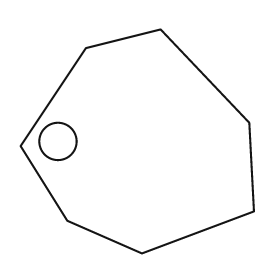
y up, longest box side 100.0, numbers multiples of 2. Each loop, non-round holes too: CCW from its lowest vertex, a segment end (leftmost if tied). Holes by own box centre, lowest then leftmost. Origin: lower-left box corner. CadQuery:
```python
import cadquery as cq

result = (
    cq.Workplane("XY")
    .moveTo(52.0, 0.0)
    .lineTo(100.0, 18.0)
    .lineTo(98.0, 56.0)
    .lineTo(60.0, 96.0)
    .lineTo(28.0, 88.0)
    .lineTo(0.0, 46.0)
    .lineTo(20.0, 14.0)
    .close()
    .moveTo(16.0, 48.0)
    .circle(8.0)
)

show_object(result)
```